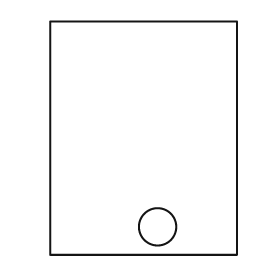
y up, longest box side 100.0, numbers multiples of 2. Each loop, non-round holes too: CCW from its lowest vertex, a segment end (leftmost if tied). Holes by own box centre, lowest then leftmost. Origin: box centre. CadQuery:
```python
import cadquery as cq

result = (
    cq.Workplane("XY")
    .moveTo(-40.0, -50.0)
    .lineTo(40.0, -50.0)
    .lineTo(40.0, 50.0)
    .lineTo(-40.0, 50.0)
    .close()
    .moveTo(6.0, -38.0)
    .circle(8.0)
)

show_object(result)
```